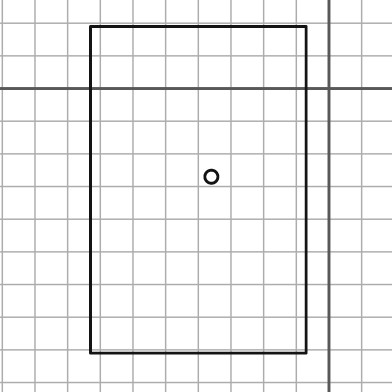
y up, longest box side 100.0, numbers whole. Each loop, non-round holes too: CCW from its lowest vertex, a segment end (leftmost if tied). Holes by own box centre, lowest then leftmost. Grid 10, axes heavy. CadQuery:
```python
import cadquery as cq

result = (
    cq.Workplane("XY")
    .moveTo(-73.0, -81.0)
    .lineTo(-7.0, -81.0)
    .lineTo(-7.0, 19.0)
    .lineTo(-73.0, 19.0)
    .close()
    .moveTo(-36.0, -27.0)
    .circle(2.0)
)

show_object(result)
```